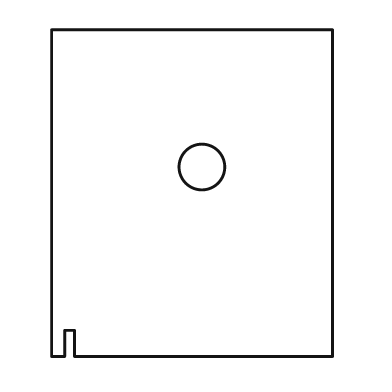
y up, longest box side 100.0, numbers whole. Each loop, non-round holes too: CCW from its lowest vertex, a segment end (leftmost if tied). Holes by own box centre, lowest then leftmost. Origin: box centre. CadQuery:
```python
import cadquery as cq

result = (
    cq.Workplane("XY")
    .moveTo(-43.0, -50.0)
    .lineTo(-39.0, -50.0)
    .lineTo(-39.0, -42.0)
    .lineTo(-36.0, -42.0)
    .lineTo(-36.0, -50.0)
    .lineTo(43.0, -50.0)
    .lineTo(43.0, 50.0)
    .lineTo(-43.0, 50.0)
    .close()
    .moveTo(3.0, 8.0)
    .circle(7.0)
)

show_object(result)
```